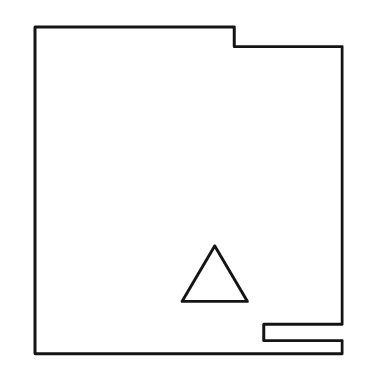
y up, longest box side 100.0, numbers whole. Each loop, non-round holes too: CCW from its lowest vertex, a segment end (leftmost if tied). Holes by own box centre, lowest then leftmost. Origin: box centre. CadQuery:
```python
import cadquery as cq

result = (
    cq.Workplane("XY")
    .moveTo(-47.0, -50.0)
    .lineTo(47.0, -50.0)
    .lineTo(47.0, -46.0)
    .lineTo(23.0, -46.0)
    .lineTo(23.0, -41.0)
    .lineTo(47.0, -41.0)
    .lineTo(47.0, 44.0)
    .lineTo(14.0, 44.0)
    .lineTo(14.0, 50.0)
    .lineTo(-47.0, 50.0)
    .close()
    .moveTo(-2.0, -34.0)
    .lineTo(18.0, -34.0)
    .lineTo(8.0, -17.0)
    .close()
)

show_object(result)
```